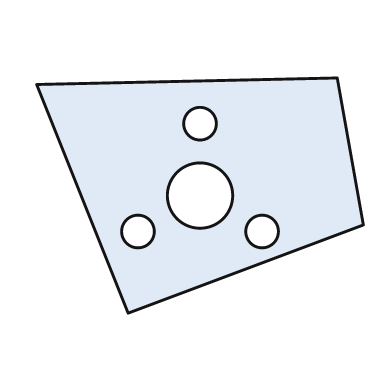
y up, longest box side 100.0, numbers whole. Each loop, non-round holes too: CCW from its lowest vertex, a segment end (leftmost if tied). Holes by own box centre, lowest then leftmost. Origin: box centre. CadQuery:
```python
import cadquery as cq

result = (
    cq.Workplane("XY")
    .moveTo(-22.0, -36.0)
    .lineTo(50.0, -9.0)
    .lineTo(42.0, 36.0)
    .lineTo(-50.0, 34.0)
    .close()
    .moveTo(-19.0, -11.0)
    .circle(5.0)
    .moveTo(19.0, -11.0)
    .circle(5.0)
    .moveTo(0.0, 0.0)
    .circle(10.0)
    .moveTo(0.0, 22.0)
    .circle(5.0)
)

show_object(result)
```